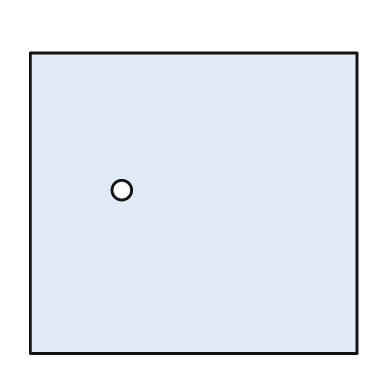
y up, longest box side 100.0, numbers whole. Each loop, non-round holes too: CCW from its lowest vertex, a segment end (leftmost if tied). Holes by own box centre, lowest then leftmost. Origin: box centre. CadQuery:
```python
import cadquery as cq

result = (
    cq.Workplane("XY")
    .moveTo(-50.0, -46.0)
    .lineTo(50.0, -46.0)
    .lineTo(50.0, 46.0)
    .lineTo(-50.0, 46.0)
    .close()
    .moveTo(-22.0, 4.0)
    .circle(3.0)
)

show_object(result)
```